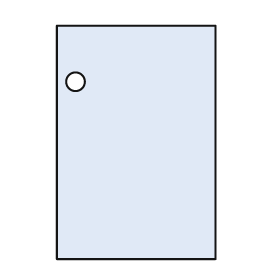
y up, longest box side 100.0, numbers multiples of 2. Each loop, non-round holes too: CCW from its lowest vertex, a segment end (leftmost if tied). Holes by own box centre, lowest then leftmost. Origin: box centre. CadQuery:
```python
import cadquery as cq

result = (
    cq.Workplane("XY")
    .moveTo(-34.0, -50.0)
    .lineTo(34.0, -50.0)
    .lineTo(34.0, 50.0)
    .lineTo(-34.0, 50.0)
    .close()
    .moveTo(-26.0, 26.0)
    .circle(4.0)
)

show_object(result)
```